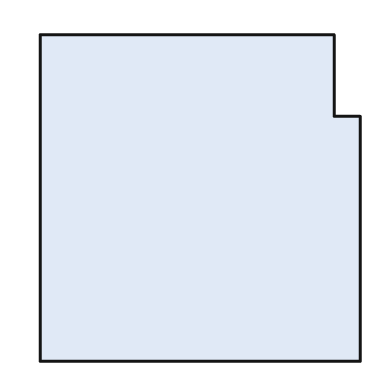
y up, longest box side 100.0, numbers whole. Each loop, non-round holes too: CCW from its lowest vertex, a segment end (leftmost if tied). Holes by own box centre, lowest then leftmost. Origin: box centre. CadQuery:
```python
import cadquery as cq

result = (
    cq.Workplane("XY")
    .moveTo(-49.0, -50.0)
    .lineTo(49.0, -50.0)
    .lineTo(49.0, 25.0)
    .lineTo(41.0, 25.0)
    .lineTo(41.0, 50.0)
    .lineTo(-49.0, 50.0)
    .close()
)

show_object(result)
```